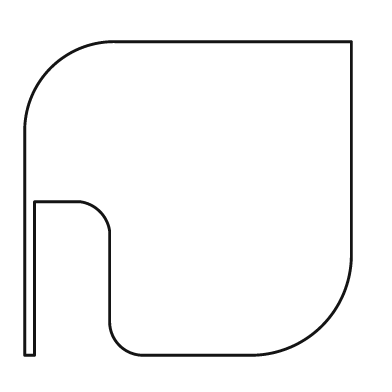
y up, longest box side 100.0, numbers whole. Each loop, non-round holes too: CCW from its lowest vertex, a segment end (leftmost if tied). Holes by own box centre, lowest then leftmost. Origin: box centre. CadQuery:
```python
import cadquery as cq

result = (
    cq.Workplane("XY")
    .moveTo(-50.0, -48.0)
    .lineTo(-47.0, -48.0)
    .lineTo(-47.0, -1.0)
    .lineTo(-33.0, -1.0)
    .threePointArc((-27.0, -4.0), (-24.0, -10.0))
    .lineTo(-24.0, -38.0)
    .threePointArc((-21.0, -45.0), (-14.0, -48.0))
    .lineTo(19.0, -48.0)
    .threePointArc((41.0, -39.0), (50.0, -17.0))
    .lineTo(50.0, 48.0)
    .lineTo(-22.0, 48.0)
    .threePointArc((-42.0, 40.0), (-50.0, 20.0))
    .close()
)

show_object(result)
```